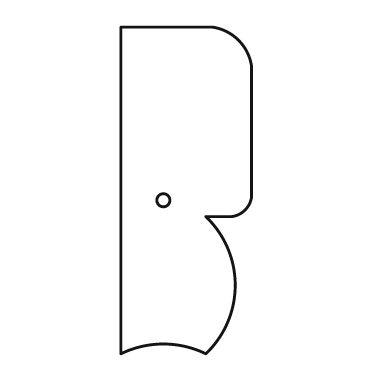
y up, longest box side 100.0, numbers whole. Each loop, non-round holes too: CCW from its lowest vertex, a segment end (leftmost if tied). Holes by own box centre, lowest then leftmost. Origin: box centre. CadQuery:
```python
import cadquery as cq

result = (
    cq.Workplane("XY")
    .moveTo(-20.0, -50.0)
    .threePointArc((-7.0, -47.0), (6.0, -50.0))
    .threePointArc((15.0, -29.0), (6.0, -8.0))
    .lineTo(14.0, -8.0)
    .threePointArc((18.0, -6.0), (20.0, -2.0))
    .lineTo(20.0, 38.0)
    .threePointArc((16.0, 46.0), (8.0, 50.0))
    .lineTo(-20.0, 50.0)
    .close()
    .moveTo(-7.0, -3.0)
    .circle(2.0)
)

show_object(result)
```